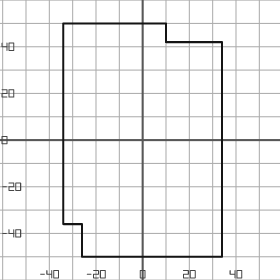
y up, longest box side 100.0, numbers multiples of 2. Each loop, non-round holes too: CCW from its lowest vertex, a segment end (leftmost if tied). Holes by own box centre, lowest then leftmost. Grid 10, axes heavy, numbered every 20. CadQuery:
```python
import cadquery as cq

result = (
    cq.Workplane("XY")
    .moveTo(-26.0, -50.0)
    .lineTo(34.0, -50.0)
    .lineTo(34.0, 42.0)
    .lineTo(10.0, 42.0)
    .lineTo(10.0, 50.0)
    .lineTo(-34.0, 50.0)
    .lineTo(-34.0, -36.0)
    .lineTo(-26.0, -36.0)
    .close()
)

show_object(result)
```